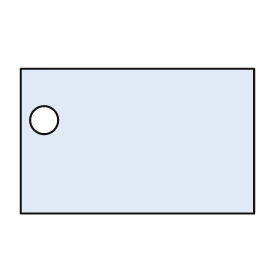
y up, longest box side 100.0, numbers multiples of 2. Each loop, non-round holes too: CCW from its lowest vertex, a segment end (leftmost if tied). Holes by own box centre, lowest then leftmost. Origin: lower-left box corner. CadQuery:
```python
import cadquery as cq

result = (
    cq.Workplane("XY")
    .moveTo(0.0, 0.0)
    .lineTo(100.0, 0.0)
    .lineTo(100.0, 62.0)
    .lineTo(0.0, 62.0)
    .close()
    .moveTo(10.0, 40.0)
    .circle(6.0)
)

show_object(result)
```